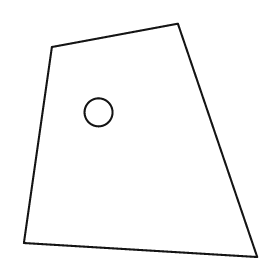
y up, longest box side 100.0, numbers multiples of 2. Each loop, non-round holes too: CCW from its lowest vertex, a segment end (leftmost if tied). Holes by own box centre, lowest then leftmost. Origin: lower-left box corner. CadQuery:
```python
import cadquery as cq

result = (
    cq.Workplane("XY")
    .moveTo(100.0, 0.0)
    .lineTo(66.0, 100.0)
    .lineTo(12.0, 90.0)
    .lineTo(0.0, 6.0)
    .close()
    .moveTo(32.0, 62.0)
    .circle(6.0)
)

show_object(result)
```